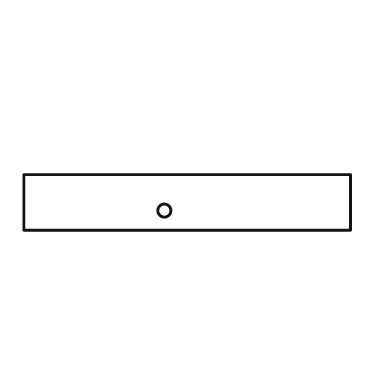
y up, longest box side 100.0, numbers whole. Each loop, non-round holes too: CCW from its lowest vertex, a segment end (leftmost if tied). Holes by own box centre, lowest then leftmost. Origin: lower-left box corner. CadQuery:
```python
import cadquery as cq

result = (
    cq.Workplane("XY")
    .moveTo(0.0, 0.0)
    .lineTo(100.0, 0.0)
    .lineTo(100.0, 17.0)
    .lineTo(0.0, 17.0)
    .close()
    .moveTo(43.0, 6.0)
    .circle(2.0)
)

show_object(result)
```